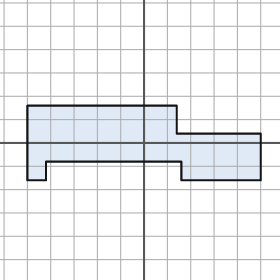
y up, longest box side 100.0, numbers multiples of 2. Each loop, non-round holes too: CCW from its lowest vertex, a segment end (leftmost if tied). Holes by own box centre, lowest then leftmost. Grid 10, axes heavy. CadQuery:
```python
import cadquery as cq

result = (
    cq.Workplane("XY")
    .moveTo(-50.0, -16.0)
    .lineTo(-42.0, -16.0)
    .lineTo(-42.0, -8.0)
    .lineTo(16.0, -8.0)
    .lineTo(16.0, -16.0)
    .lineTo(50.0, -16.0)
    .lineTo(50.0, 4.0)
    .lineTo(14.0, 4.0)
    .lineTo(14.0, 16.0)
    .lineTo(-50.0, 16.0)
    .close()
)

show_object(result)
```